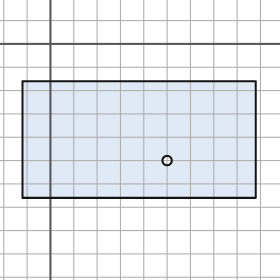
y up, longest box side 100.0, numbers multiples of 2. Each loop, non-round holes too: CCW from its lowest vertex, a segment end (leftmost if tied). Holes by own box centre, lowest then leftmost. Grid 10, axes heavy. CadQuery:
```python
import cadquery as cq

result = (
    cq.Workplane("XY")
    .moveTo(-12.0, -66.0)
    .lineTo(88.0, -66.0)
    .lineTo(88.0, -16.0)
    .lineTo(-12.0, -16.0)
    .close()
    .moveTo(50.0, -50.0)
    .circle(2.0)
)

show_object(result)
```